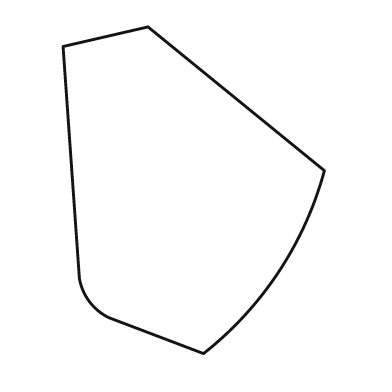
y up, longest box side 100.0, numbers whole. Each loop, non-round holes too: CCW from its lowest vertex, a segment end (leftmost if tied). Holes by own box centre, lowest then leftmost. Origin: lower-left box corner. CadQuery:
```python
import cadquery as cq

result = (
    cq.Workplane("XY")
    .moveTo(43.0, 0.0)
    .threePointArc((66.0, 25.0), (80.0, 56.0))
    .lineTo(26.0, 100.0)
    .lineTo(0.0, 94.0)
    .lineTo(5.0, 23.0)
    .threePointArc((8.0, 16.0), (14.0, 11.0))
    .close()
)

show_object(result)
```